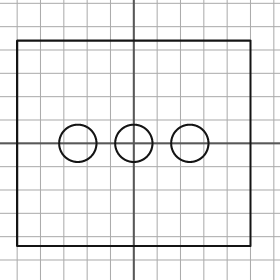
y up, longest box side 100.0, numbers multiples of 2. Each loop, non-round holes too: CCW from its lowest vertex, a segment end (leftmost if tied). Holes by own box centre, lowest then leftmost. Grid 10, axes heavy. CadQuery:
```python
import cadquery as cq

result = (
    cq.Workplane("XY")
    .moveTo(-50.0, -44.0)
    .lineTo(50.0, -44.0)
    .lineTo(50.0, 44.0)
    .lineTo(-50.0, 44.0)
    .close()
    .moveTo(-24.0, 0.0)
    .circle(8.0)
    .moveTo(0.0, 0.0)
    .circle(8.0)
    .moveTo(24.0, 0.0)
    .circle(8.0)
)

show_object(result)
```